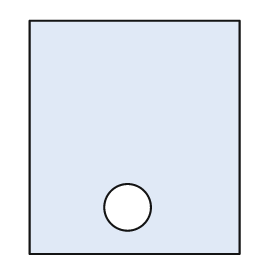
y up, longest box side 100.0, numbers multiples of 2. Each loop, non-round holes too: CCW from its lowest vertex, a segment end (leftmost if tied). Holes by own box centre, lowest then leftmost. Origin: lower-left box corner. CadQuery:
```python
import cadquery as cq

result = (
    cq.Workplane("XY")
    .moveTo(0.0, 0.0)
    .lineTo(90.0, 0.0)
    .lineTo(90.0, 100.0)
    .lineTo(0.0, 100.0)
    .close()
    .moveTo(42.0, 20.0)
    .circle(10.0)
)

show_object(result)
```